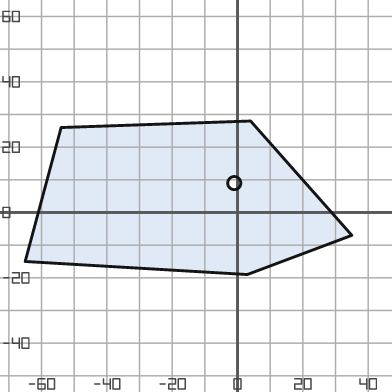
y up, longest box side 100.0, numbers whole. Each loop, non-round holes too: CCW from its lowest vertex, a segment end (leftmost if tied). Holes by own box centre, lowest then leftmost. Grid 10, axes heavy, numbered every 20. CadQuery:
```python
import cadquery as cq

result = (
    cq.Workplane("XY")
    .moveTo(3.0, -19.0)
    .lineTo(35.0, -7.0)
    .lineTo(4.0, 28.0)
    .lineTo(-54.0, 26.0)
    .lineTo(-65.0, -15.0)
    .close()
    .moveTo(-1.0, 9.0)
    .circle(2.0)
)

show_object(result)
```